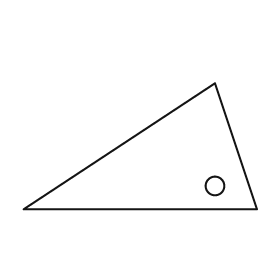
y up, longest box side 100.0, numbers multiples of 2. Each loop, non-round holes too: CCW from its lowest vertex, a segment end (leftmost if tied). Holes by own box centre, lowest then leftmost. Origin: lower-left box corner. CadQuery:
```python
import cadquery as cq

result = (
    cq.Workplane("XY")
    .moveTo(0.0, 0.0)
    .lineTo(100.0, 0.0)
    .lineTo(82.0, 54.0)
    .close()
    .moveTo(82.0, 10.0)
    .circle(4.0)
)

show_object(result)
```